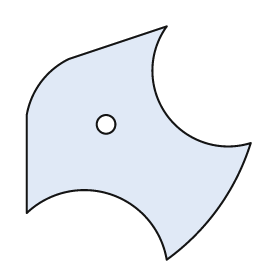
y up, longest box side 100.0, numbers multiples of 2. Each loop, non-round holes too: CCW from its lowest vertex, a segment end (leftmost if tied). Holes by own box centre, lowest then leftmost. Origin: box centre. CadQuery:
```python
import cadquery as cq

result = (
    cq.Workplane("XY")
    .moveTo(12.0, -50.0)
    .threePointArc((34.0, -28.0), (48.0, 0.0))
    .threePointArc((12.0, 12.0), (12.0, 50.0))
    .lineTo(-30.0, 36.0)
    .threePointArc((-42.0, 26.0), (-48.0, 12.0))
    .lineTo(-48.0, -30.0)
    .threePointArc((-12.0, -22.0), (12.0, -50.0))
    .close()
    .moveTo(-14.0, 8.0)
    .circle(4.0)
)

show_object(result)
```